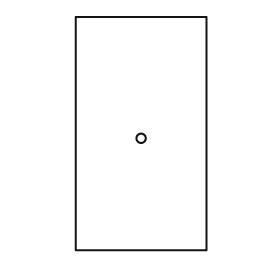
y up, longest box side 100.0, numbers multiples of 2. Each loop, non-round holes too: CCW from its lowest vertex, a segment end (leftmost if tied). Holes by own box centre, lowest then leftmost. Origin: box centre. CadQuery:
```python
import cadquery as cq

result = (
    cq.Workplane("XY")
    .moveTo(-28.0, -50.0)
    .lineTo(28.0, -50.0)
    .lineTo(28.0, 50.0)
    .lineTo(-28.0, 50.0)
    .close()
    .moveTo(0.0, -2.0)
    .circle(2.0)
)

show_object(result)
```